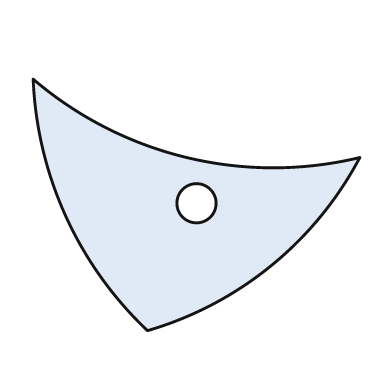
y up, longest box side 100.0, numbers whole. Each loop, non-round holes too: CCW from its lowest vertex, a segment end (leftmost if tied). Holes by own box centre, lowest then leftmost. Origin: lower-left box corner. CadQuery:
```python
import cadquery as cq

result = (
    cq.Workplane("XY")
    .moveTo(35.0, 0.0)
    .threePointArc((73.0, 20.0), (100.0, 53.0))
    .threePointArc((47.0, 53.0), (0.0, 77.0))
    .threePointArc((10.0, 35.0), (35.0, 0.0))
    .close()
    .moveTo(50.0, 39.0)
    .circle(6.0)
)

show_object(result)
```